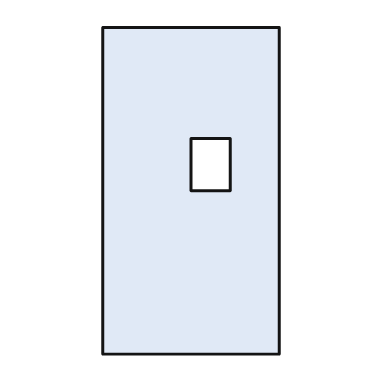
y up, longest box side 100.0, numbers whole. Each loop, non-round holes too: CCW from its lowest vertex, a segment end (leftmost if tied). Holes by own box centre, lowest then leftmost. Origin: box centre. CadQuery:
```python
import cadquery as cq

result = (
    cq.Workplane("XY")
    .moveTo(-27.0, -50.0)
    .lineTo(27.0, -50.0)
    .lineTo(27.0, 50.0)
    .lineTo(-27.0, 50.0)
    .close()
    .moveTo(0.0, 0.0)
    .lineTo(12.0, 0.0)
    .lineTo(12.0, 16.0)
    .lineTo(0.0, 16.0)
    .close()
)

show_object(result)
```